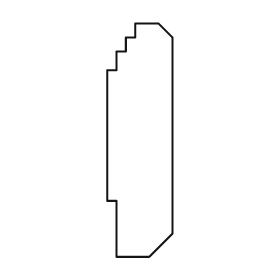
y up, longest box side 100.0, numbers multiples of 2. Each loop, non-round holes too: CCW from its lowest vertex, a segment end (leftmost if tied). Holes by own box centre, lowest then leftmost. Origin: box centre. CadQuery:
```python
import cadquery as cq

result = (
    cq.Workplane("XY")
    .moveTo(-10.0, -50.0)
    .lineTo(4.0, -50.0)
    .lineTo(14.0, -40.0)
    .lineTo(14.0, 44.0)
    .lineTo(8.0, 50.0)
    .lineTo(-2.0, 50.0)
    .lineTo(-2.0, 44.0)
    .lineTo(-6.0, 44.0)
    .lineTo(-6.0, 38.0)
    .lineTo(-10.0, 38.0)
    .lineTo(-10.0, 30.0)
    .lineTo(-14.0, 30.0)
    .lineTo(-14.0, -26.0)
    .lineTo(-10.0, -26.0)
    .close()
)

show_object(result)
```